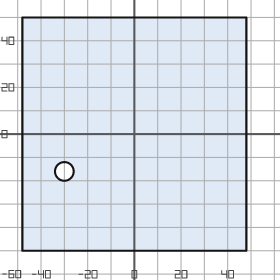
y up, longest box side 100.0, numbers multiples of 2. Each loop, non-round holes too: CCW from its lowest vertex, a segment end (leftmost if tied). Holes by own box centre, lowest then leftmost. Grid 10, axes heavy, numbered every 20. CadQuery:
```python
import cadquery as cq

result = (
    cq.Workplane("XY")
    .moveTo(-48.0, -50.0)
    .lineTo(48.0, -50.0)
    .lineTo(48.0, 50.0)
    .lineTo(-48.0, 50.0)
    .close()
    .moveTo(-30.0, -16.0)
    .circle(4.0)
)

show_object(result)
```